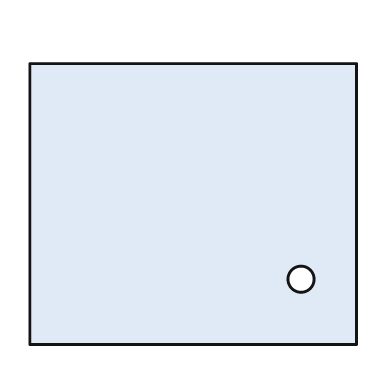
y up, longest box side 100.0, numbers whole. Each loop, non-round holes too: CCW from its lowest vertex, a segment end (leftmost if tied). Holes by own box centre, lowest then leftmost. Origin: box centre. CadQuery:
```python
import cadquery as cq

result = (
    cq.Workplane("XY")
    .moveTo(-50.0, -43.0)
    .lineTo(50.0, -43.0)
    .lineTo(50.0, 43.0)
    .lineTo(-50.0, 43.0)
    .close()
    .moveTo(33.0, -23.0)
    .circle(4.0)
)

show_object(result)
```